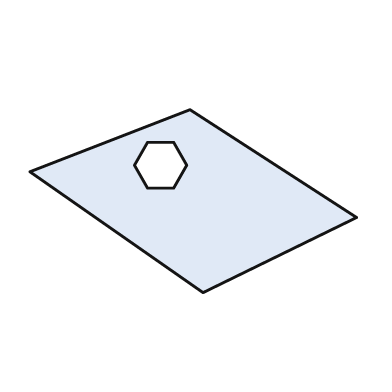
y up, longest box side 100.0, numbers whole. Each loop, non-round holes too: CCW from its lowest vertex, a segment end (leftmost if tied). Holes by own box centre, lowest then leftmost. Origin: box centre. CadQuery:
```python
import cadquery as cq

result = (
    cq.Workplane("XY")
    .moveTo(3.0, -28.0)
    .lineTo(50.0, -5.0)
    .lineTo(-1.0, 28.0)
    .lineTo(-50.0, 9.0)
    .close()
    .moveTo(-14.0, 4.0)
    .lineTo(-6.0, 4.0)
    .lineTo(-2.0, 11.0)
    .lineTo(-6.0, 18.0)
    .lineTo(-14.0, 18.0)
    .lineTo(-18.0, 11.0)
    .close()
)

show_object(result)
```